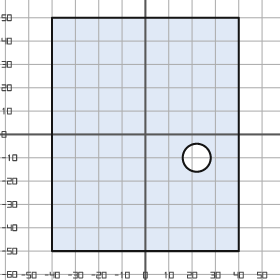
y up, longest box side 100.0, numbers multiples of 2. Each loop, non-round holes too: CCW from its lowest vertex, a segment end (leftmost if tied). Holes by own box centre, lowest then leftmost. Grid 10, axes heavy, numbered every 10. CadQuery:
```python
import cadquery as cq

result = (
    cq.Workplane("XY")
    .moveTo(-40.0, -50.0)
    .lineTo(40.0, -50.0)
    .lineTo(40.0, 50.0)
    .lineTo(-40.0, 50.0)
    .close()
    .moveTo(22.0, -10.0)
    .circle(6.0)
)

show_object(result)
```